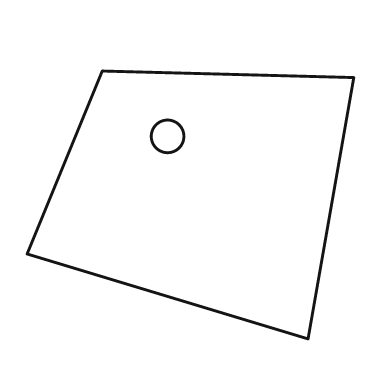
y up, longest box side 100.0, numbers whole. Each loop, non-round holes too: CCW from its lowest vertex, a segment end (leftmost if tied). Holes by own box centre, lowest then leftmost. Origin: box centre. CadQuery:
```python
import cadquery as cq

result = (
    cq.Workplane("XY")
    .moveTo(36.0, -41.0)
    .lineTo(50.0, 39.0)
    .lineTo(-27.0, 41.0)
    .lineTo(-50.0, -15.0)
    .close()
    .moveTo(-7.0, 21.0)
    .circle(5.0)
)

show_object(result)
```